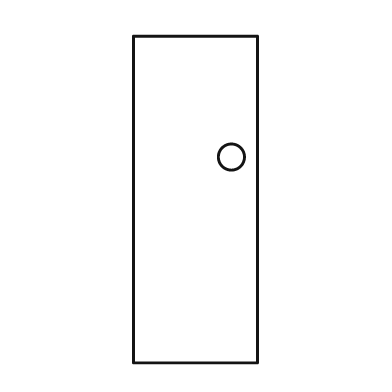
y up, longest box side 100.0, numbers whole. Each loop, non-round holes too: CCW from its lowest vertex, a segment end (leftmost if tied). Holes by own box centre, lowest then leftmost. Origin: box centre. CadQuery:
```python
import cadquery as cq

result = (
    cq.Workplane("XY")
    .moveTo(-19.0, -50.0)
    .lineTo(19.0, -50.0)
    .lineTo(19.0, 50.0)
    .lineTo(-19.0, 50.0)
    .close()
    .moveTo(11.0, 13.0)
    .circle(4.0)
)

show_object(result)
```